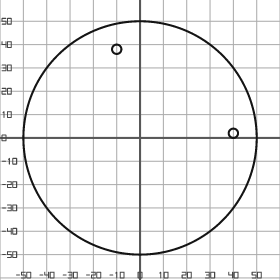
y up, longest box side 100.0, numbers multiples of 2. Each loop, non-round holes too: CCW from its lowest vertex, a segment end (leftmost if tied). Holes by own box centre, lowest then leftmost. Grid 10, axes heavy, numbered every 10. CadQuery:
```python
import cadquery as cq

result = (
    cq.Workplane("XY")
    .moveTo(0.0, 0.0)
    .circle(50.0)
    .moveTo(40.0, 2.0)
    .circle(2.0)
    .moveTo(-10.0, 38.0)
    .circle(2.0)
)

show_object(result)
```